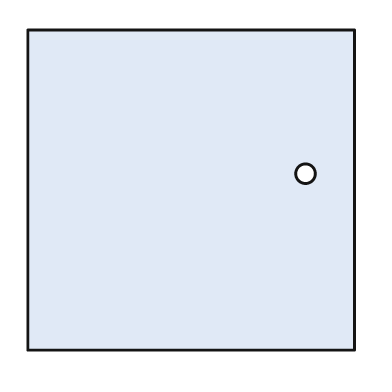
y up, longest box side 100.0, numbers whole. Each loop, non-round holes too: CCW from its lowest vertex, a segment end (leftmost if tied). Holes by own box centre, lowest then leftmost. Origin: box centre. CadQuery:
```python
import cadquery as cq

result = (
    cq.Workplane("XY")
    .moveTo(-50.0, -49.0)
    .lineTo(50.0, -49.0)
    .lineTo(50.0, 49.0)
    .lineTo(-50.0, 49.0)
    .close()
    .moveTo(35.0, 5.0)
    .circle(3.0)
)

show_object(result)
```